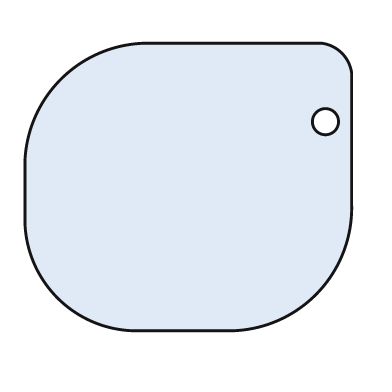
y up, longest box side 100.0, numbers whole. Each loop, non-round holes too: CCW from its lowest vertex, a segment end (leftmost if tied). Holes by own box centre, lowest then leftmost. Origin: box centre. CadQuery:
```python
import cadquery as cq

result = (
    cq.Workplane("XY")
    .moveTo(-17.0, -44.0)
    .lineTo(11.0, -44.0)
    .threePointArc((39.0, -33.0), (50.0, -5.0))
    .lineTo(50.0, 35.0)
    .threePointArc((47.0, 41.0), (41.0, 44.0))
    .lineTo(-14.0, 44.0)
    .threePointArc((-39.0, 33.0), (-50.0, 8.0))
    .lineTo(-50.0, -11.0)
    .threePointArc((-40.0, -34.0), (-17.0, -44.0))
    .close()
    .moveTo(42.0, 20.0)
    .circle(4.0)
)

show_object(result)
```